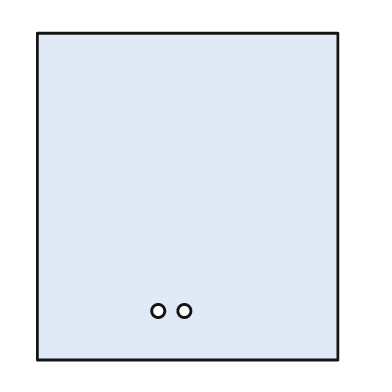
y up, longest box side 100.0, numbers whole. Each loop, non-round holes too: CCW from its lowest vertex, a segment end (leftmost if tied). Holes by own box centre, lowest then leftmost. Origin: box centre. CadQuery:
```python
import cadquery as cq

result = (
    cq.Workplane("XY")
    .moveTo(-46.0, -50.0)
    .lineTo(46.0, -50.0)
    .lineTo(46.0, 50.0)
    .lineTo(-46.0, 50.0)
    .close()
    .moveTo(-9.0, -35.0)
    .circle(2.0)
    .moveTo(-1.0, -35.0)
    .circle(2.0)
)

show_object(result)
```